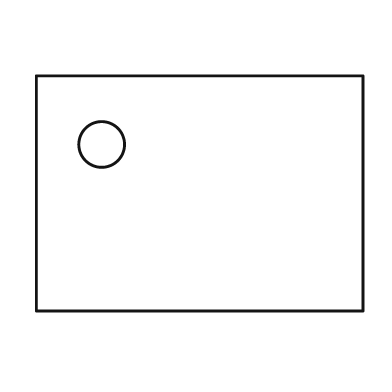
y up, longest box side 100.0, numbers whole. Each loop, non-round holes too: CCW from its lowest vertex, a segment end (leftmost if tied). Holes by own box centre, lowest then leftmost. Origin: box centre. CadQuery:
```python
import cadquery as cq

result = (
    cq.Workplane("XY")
    .moveTo(-50.0, -36.0)
    .lineTo(50.0, -36.0)
    .lineTo(50.0, 36.0)
    .lineTo(-50.0, 36.0)
    .close()
    .moveTo(-30.0, 15.0)
    .circle(7.0)
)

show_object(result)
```